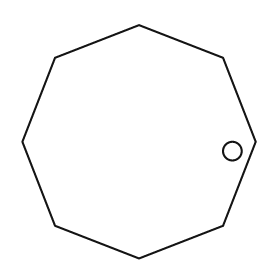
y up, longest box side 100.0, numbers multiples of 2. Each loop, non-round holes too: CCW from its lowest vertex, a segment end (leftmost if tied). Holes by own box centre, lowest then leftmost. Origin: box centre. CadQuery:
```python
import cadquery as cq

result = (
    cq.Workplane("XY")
    .moveTo(0.0, -50.0)
    .lineTo(36.0, -36.0)
    .lineTo(50.0, 0.0)
    .lineTo(36.0, 36.0)
    .lineTo(0.0, 50.0)
    .lineTo(-36.0, 36.0)
    .lineTo(-50.0, 0.0)
    .lineTo(-36.0, -36.0)
    .close()
    .moveTo(40.0, -4.0)
    .circle(4.0)
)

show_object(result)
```